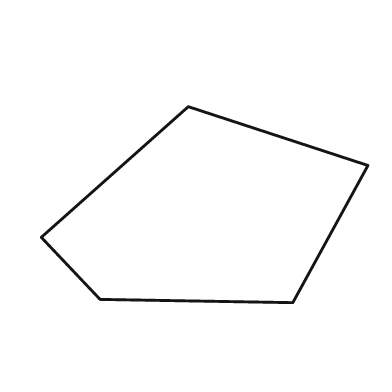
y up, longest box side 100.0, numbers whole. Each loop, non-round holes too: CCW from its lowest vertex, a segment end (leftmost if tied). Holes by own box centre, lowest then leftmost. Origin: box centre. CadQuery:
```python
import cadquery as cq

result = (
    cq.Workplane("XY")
    .moveTo(27.0, -30.0)
    .lineTo(50.0, 12.0)
    .lineTo(-5.0, 30.0)
    .lineTo(-50.0, -10.0)
    .lineTo(-32.0, -29.0)
    .close()
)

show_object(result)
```